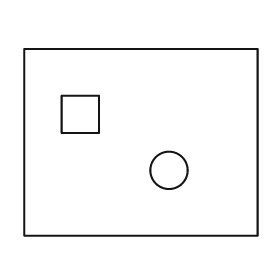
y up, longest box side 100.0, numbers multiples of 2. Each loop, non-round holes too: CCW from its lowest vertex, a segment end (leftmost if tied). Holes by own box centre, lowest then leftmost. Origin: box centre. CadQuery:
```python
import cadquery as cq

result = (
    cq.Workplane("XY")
    .moveTo(-50.0, -40.0)
    .lineTo(50.0, -40.0)
    .lineTo(50.0, 40.0)
    .lineTo(-50.0, 40.0)
    .close()
    .moveTo(12.0, -12.0)
    .circle(8.0)
    .moveTo(-34.0, 4.0)
    .lineTo(-18.0, 4.0)
    .lineTo(-18.0, 20.0)
    .lineTo(-34.0, 20.0)
    .close()
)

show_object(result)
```